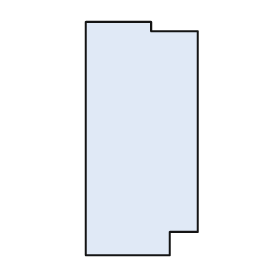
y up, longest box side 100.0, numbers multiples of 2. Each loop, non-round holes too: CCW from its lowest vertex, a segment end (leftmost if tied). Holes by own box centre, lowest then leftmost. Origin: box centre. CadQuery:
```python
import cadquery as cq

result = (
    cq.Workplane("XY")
    .moveTo(-24.0, -50.0)
    .lineTo(12.0, -50.0)
    .lineTo(12.0, -40.0)
    .lineTo(24.0, -40.0)
    .lineTo(24.0, 46.0)
    .lineTo(4.0, 46.0)
    .lineTo(4.0, 50.0)
    .lineTo(-24.0, 50.0)
    .close()
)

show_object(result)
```